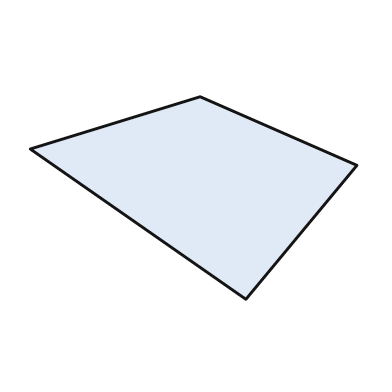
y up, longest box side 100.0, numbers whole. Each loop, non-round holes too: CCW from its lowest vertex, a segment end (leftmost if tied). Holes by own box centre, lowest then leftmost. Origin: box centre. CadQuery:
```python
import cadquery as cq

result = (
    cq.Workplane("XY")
    .moveTo(16.0, -31.0)
    .lineTo(50.0, 10.0)
    .lineTo(2.0, 31.0)
    .lineTo(-50.0, 15.0)
    .close()
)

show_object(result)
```